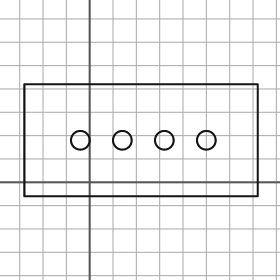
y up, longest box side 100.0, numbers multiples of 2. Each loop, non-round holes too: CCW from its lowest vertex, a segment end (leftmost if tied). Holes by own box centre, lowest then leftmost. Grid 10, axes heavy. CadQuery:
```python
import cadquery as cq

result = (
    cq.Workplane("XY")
    .moveTo(-28.0, -6.0)
    .lineTo(72.0, -6.0)
    .lineTo(72.0, 42.0)
    .lineTo(-28.0, 42.0)
    .close()
    .moveTo(-4.0, 18.0)
    .circle(4.0)
    .moveTo(14.0, 18.0)
    .circle(4.0)
    .moveTo(32.0, 18.0)
    .circle(4.0)
    .moveTo(50.0, 18.0)
    .circle(4.0)
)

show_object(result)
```